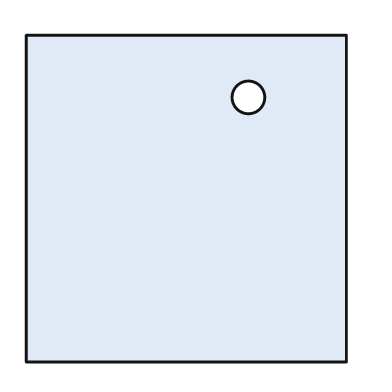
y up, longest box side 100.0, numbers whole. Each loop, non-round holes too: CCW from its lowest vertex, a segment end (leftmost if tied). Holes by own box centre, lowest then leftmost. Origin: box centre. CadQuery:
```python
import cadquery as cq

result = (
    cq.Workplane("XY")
    .moveTo(-49.0, -50.0)
    .lineTo(49.0, -50.0)
    .lineTo(49.0, 50.0)
    .lineTo(-49.0, 50.0)
    .close()
    .moveTo(19.0, 31.0)
    .circle(5.0)
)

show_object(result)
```